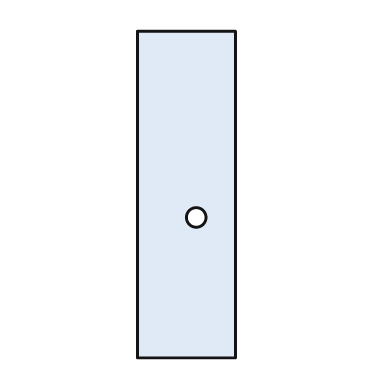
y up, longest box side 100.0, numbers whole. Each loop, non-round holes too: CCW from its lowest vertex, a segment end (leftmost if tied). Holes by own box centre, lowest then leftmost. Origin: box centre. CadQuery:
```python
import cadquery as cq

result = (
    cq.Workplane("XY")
    .moveTo(-15.0, -50.0)
    .lineTo(15.0, -50.0)
    .lineTo(15.0, 50.0)
    .lineTo(-15.0, 50.0)
    .close()
    .moveTo(3.0, -7.0)
    .circle(3.0)
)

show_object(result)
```